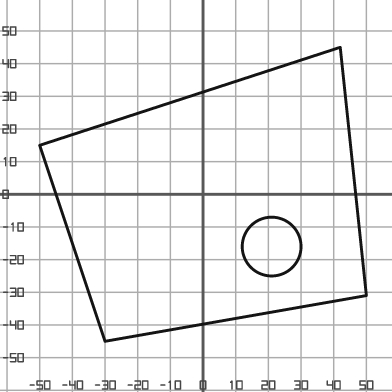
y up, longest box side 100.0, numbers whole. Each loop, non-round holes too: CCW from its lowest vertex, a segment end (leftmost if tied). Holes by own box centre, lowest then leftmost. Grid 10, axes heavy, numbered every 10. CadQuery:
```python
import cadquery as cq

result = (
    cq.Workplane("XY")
    .moveTo(-30.0, -45.0)
    .lineTo(50.0, -31.0)
    .lineTo(42.0, 45.0)
    .lineTo(-50.0, 15.0)
    .close()
    .moveTo(21.0, -16.0)
    .circle(9.0)
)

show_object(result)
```